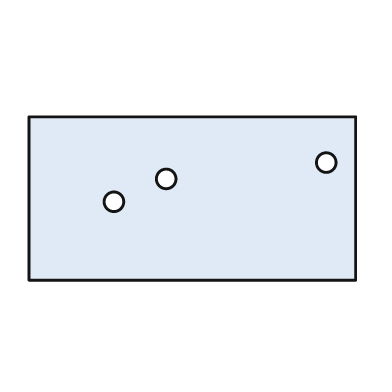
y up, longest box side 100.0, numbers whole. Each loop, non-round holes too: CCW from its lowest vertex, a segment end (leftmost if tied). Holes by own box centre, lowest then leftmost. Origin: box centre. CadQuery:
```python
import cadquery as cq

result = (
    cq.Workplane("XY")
    .moveTo(-50.0, -25.0)
    .lineTo(50.0, -25.0)
    .lineTo(50.0, 25.0)
    .lineTo(-50.0, 25.0)
    .close()
    .moveTo(-24.0, -1.0)
    .circle(3.0)
    .moveTo(-8.0, 6.0)
    .circle(3.0)
    .moveTo(41.0, 11.0)
    .circle(3.0)
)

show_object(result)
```